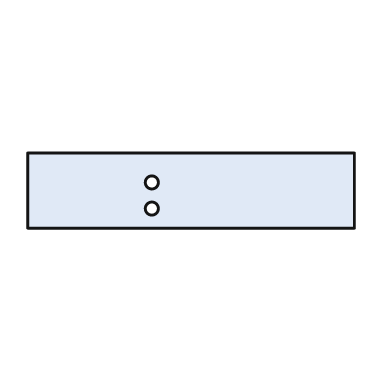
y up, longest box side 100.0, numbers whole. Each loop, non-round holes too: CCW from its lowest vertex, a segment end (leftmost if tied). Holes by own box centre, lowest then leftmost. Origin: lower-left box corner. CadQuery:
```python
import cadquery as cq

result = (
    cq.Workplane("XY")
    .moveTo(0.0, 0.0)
    .lineTo(100.0, 0.0)
    .lineTo(100.0, 23.0)
    .lineTo(0.0, 23.0)
    .close()
    .moveTo(38.0, 6.0)
    .circle(2.0)
    .moveTo(38.0, 14.0)
    .circle(2.0)
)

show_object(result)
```